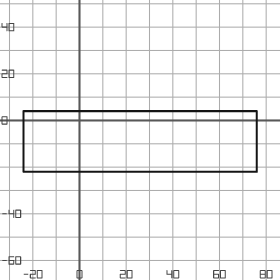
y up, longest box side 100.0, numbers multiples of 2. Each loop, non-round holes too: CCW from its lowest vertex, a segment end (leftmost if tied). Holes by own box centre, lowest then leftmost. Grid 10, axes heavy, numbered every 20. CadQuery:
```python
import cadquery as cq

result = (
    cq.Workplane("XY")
    .moveTo(-24.0, -22.0)
    .lineTo(76.0, -22.0)
    .lineTo(76.0, 4.0)
    .lineTo(-24.0, 4.0)
    .close()
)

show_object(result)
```